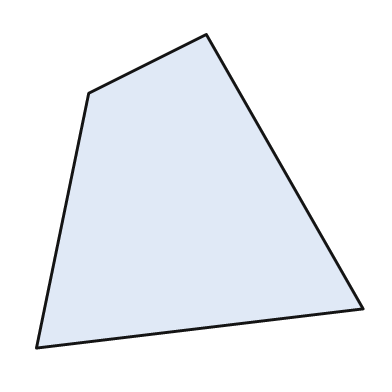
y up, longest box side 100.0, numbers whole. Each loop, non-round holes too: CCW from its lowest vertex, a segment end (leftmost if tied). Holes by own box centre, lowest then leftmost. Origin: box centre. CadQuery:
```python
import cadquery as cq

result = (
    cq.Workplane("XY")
    .moveTo(-50.0, -48.0)
    .lineTo(50.0, -36.0)
    .lineTo(2.0, 48.0)
    .lineTo(-34.0, 30.0)
    .close()
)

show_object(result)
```